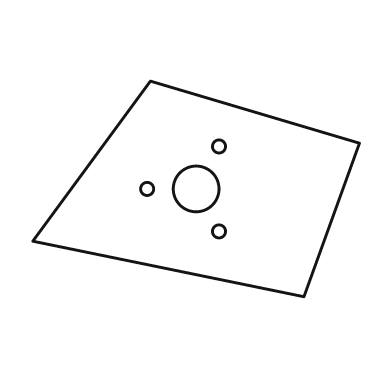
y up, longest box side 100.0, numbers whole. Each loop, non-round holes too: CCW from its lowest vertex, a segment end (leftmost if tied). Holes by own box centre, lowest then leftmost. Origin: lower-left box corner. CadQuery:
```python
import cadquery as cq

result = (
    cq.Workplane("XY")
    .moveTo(83.0, 0.0)
    .lineTo(100.0, 47.0)
    .lineTo(36.0, 66.0)
    .lineTo(0.0, 17.0)
    .close()
    .moveTo(57.0, 20.0)
    .circle(2.0)
    .moveTo(35.0, 33.0)
    .circle(2.0)
    .moveTo(50.0, 33.0)
    .circle(7.0)
    .moveTo(57.0, 46.0)
    .circle(2.0)
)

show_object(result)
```